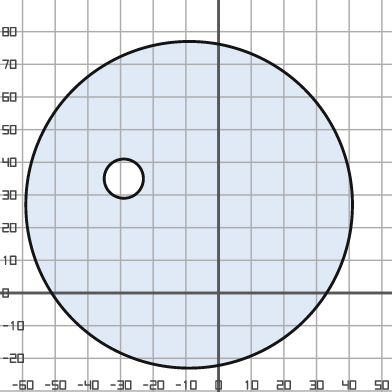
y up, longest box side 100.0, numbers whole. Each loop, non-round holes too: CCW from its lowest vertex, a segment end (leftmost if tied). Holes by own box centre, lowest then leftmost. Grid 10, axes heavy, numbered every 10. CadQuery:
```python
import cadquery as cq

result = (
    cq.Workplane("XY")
    .moveTo(-9.0, 27.0)
    .circle(50.0)
    .moveTo(-29.0, 35.0)
    .circle(6.0)
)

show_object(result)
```